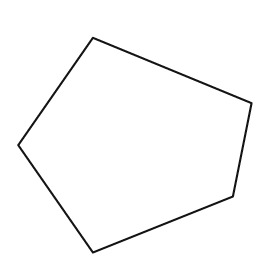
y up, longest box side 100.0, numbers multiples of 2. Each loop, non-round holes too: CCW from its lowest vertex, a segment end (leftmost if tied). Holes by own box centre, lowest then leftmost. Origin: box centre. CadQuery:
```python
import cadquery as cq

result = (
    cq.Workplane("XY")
    .moveTo(-18.0, -46.0)
    .lineTo(42.0, -22.0)
    .lineTo(50.0, 18.0)
    .lineTo(-18.0, 46.0)
    .lineTo(-50.0, 0.0)
    .close()
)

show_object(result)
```